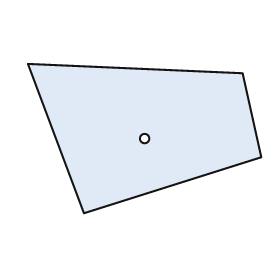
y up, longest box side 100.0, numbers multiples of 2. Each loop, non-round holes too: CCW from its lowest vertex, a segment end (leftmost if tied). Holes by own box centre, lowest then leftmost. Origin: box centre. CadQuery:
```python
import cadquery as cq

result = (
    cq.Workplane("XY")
    .moveTo(-26.0, -32.0)
    .lineTo(50.0, -8.0)
    .lineTo(42.0, 28.0)
    .lineTo(-50.0, 32.0)
    .close()
    .moveTo(0.0, 0.0)
    .circle(2.0)
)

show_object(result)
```